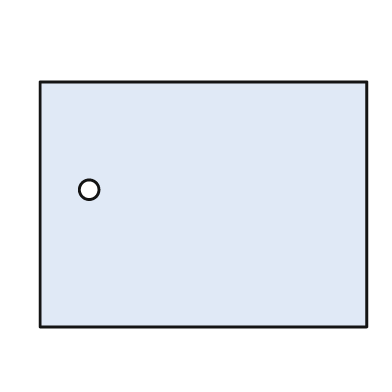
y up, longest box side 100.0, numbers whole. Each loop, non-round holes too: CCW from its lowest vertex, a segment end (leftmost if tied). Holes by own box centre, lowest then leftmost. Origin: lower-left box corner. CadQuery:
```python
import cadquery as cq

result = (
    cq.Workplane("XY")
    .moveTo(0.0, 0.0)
    .lineTo(100.0, 0.0)
    .lineTo(100.0, 75.0)
    .lineTo(0.0, 75.0)
    .close()
    .moveTo(15.0, 42.0)
    .circle(3.0)
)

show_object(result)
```